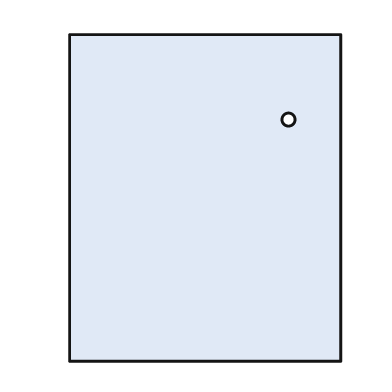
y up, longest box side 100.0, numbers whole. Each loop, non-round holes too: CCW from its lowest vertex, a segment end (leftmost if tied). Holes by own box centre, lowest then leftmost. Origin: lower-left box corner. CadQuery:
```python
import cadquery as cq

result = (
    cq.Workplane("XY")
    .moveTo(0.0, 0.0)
    .lineTo(83.0, 0.0)
    .lineTo(83.0, 100.0)
    .lineTo(0.0, 100.0)
    .close()
    .moveTo(67.0, 74.0)
    .circle(2.0)
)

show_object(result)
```